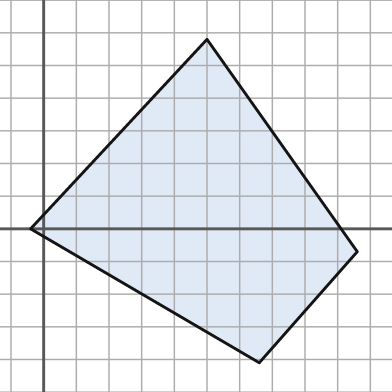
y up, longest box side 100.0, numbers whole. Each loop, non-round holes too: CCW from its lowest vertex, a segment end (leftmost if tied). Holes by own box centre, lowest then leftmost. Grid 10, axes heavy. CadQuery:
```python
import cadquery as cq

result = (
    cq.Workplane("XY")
    .moveTo(66.0, -41.0)
    .lineTo(96.0, -7.0)
    .lineTo(50.0, 58.0)
    .lineTo(-4.0, 0.0)
    .close()
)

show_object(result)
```